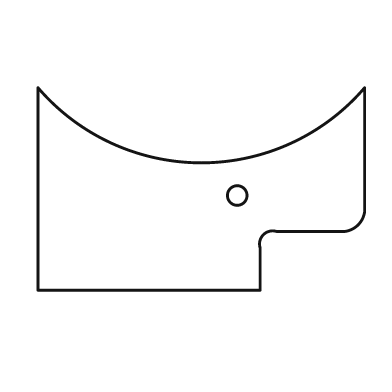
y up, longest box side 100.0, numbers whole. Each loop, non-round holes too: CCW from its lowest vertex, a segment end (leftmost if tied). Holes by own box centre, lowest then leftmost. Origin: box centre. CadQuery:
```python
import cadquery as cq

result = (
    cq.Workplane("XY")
    .moveTo(-50.0, -31.0)
    .lineTo(18.0, -31.0)
    .lineTo(18.0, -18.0)
    .threePointArc((19.0, -14.0), (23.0, -13.0))
    .lineTo(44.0, -13.0)
    .threePointArc((48.0, -11.0), (50.0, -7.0))
    .lineTo(50.0, 31.0)
    .threePointArc((0.0, 8.0), (-50.0, 31.0))
    .close()
    .moveTo(11.0, -2.0)
    .circle(3.0)
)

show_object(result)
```